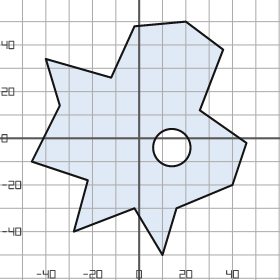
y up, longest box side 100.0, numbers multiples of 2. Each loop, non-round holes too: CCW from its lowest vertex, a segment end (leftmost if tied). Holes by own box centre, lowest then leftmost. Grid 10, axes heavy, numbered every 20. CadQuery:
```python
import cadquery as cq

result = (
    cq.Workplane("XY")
    .moveTo(10.0, -50.0)
    .lineTo(16.0, -30.0)
    .lineTo(40.0, -20.0)
    .lineTo(46.0, -2.0)
    .lineTo(26.0, 12.0)
    .lineTo(36.0, 38.0)
    .lineTo(20.0, 50.0)
    .lineTo(-2.0, 48.0)
    .lineTo(-12.0, 26.0)
    .lineTo(-40.0, 34.0)
    .lineTo(-34.0, 14.0)
    .lineTo(-46.0, -10.0)
    .lineTo(-22.0, -18.0)
    .lineTo(-28.0, -40.0)
    .lineTo(-2.0, -30.0)
    .close()
    .moveTo(14.0, -4.0)
    .circle(8.0)
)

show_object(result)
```